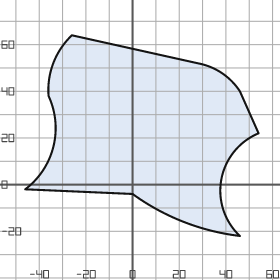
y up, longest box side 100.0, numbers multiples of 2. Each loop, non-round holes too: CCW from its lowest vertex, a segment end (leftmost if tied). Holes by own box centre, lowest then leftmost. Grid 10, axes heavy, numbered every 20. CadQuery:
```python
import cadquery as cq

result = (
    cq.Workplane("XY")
    .moveTo(46.0, -22.0)
    .threePointArc((38.0, 2.0), (54.0, 22.0))
    .lineTo(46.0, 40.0)
    .threePointArc((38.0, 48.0), (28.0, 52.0))
    .lineTo(-26.0, 64.0)
    .threePointArc((-34.0, 52.0), (-36.0, 38.0))
    .threePointArc((-34.0, 16.0), (-46.0, -2.0))
    .lineTo(0.0, -4.0)
    .threePointArc((22.0, -16.0), (46.0, -22.0))
    .close()
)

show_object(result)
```